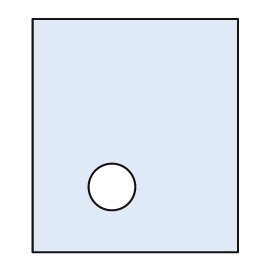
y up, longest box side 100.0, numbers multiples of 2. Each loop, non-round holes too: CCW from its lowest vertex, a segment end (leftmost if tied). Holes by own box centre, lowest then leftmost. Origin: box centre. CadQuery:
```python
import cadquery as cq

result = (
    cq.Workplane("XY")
    .moveTo(-44.0, -50.0)
    .lineTo(44.0, -50.0)
    .lineTo(44.0, 50.0)
    .lineTo(-44.0, 50.0)
    .close()
    .moveTo(-10.0, -22.0)
    .circle(10.0)
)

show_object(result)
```